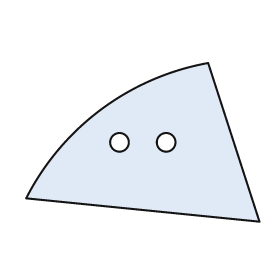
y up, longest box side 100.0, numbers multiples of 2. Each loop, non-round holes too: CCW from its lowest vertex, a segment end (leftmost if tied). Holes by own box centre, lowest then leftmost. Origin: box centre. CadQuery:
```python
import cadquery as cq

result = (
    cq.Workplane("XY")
    .moveTo(50.0, -34.0)
    .lineTo(28.0, 34.0)
    .threePointArc((-18.0, 14.0), (-50.0, -24.0))
    .close()
    .moveTo(-10.0, 0.0)
    .circle(4.0)
    .moveTo(10.0, 0.0)
    .circle(4.0)
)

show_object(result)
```